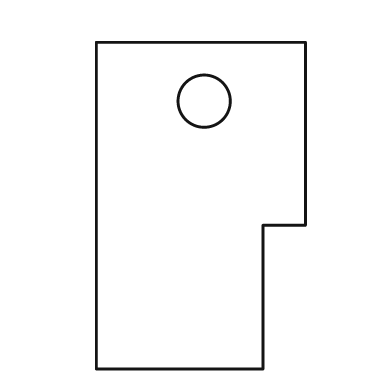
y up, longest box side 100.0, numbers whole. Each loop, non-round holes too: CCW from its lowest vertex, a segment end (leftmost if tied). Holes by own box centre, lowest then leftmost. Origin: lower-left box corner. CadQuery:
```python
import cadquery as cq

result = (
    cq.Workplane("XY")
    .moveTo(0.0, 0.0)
    .lineTo(51.0, 0.0)
    .lineTo(51.0, 44.0)
    .lineTo(64.0, 44.0)
    .lineTo(64.0, 100.0)
    .lineTo(0.0, 100.0)
    .close()
    .moveTo(33.0, 82.0)
    .circle(8.0)
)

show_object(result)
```